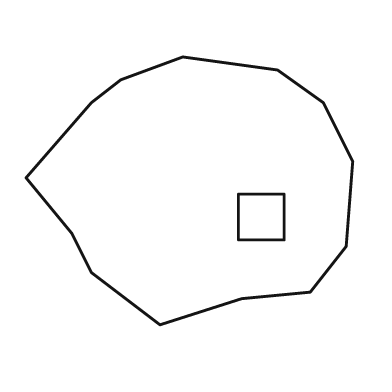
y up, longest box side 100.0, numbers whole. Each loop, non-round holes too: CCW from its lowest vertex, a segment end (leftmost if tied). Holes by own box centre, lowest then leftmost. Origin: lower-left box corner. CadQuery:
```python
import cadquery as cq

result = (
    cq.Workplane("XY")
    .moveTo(41.0, 0.0)
    .lineTo(66.0, 8.0)
    .lineTo(87.0, 10.0)
    .lineTo(98.0, 24.0)
    .lineTo(100.0, 50.0)
    .lineTo(91.0, 68.0)
    .lineTo(77.0, 78.0)
    .lineTo(48.0, 82.0)
    .lineTo(29.0, 75.0)
    .lineTo(20.0, 68.0)
    .lineTo(0.0, 45.0)
    .lineTo(14.0, 28.0)
    .lineTo(20.0, 16.0)
    .close()
    .moveTo(65.0, 26.0)
    .lineTo(79.0, 26.0)
    .lineTo(79.0, 40.0)
    .lineTo(65.0, 40.0)
    .close()
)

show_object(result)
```